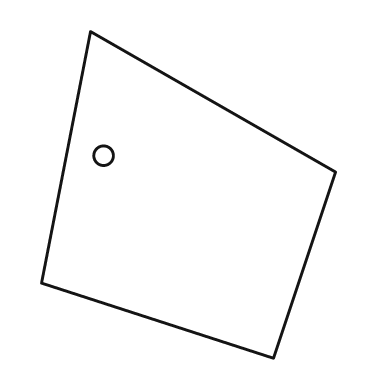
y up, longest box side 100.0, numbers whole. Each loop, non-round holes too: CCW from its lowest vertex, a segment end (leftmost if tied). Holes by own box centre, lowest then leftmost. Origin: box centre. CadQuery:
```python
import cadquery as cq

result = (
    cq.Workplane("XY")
    .moveTo(26.0, -50.0)
    .lineTo(45.0, 7.0)
    .lineTo(-30.0, 50.0)
    .lineTo(-45.0, -27.0)
    .close()
    .moveTo(-26.0, 12.0)
    .circle(3.0)
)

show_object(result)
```